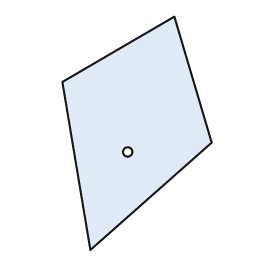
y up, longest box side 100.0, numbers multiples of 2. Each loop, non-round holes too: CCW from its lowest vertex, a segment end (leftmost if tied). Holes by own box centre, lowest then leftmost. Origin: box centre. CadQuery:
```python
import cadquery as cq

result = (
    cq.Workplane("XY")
    .moveTo(-20.0, -50.0)
    .lineTo(32.0, -4.0)
    .lineTo(16.0, 50.0)
    .lineTo(-32.0, 22.0)
    .close()
    .moveTo(-4.0, -8.0)
    .circle(2.0)
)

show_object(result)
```